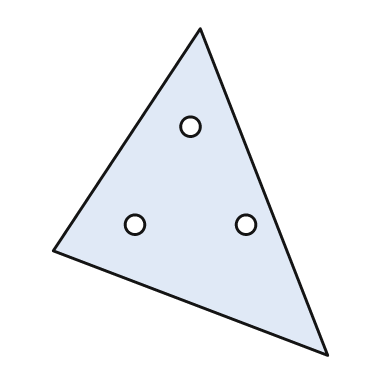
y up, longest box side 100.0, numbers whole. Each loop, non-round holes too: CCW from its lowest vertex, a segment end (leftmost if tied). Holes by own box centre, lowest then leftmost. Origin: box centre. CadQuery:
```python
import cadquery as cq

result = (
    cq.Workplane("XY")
    .moveTo(42.0, -50.0)
    .lineTo(3.0, 50.0)
    .lineTo(-42.0, -18.0)
    .close()
    .moveTo(-17.0, -10.0)
    .circle(3.0)
    .moveTo(17.0, -10.0)
    .circle(3.0)
    .moveTo(0.0, 20.0)
    .circle(3.0)
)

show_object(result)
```